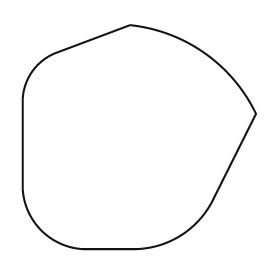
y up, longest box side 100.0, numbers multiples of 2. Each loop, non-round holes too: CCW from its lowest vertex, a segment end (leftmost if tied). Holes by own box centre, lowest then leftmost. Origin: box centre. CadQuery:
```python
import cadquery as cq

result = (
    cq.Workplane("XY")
    .moveTo(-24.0, -48.0)
    .lineTo(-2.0, -48.0)
    .threePointArc((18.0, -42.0), (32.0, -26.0))
    .lineTo(50.0, 10.0)
    .threePointArc((28.0, 36.0), (-4.0, 48.0))
    .lineTo(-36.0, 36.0)
    .threePointArc((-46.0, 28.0), (-50.0, 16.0))
    .lineTo(-50.0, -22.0)
    .threePointArc((-42.0, -40.0), (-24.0, -48.0))
    .close()
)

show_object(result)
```